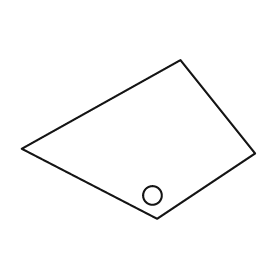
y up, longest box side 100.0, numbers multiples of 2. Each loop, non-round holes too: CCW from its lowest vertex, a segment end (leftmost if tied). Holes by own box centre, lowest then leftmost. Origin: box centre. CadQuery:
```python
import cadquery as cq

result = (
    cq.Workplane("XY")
    .moveTo(8.0, -34.0)
    .lineTo(50.0, -6.0)
    .lineTo(18.0, 34.0)
    .lineTo(-50.0, -4.0)
    .close()
    .moveTo(6.0, -24.0)
    .circle(4.0)
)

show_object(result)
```